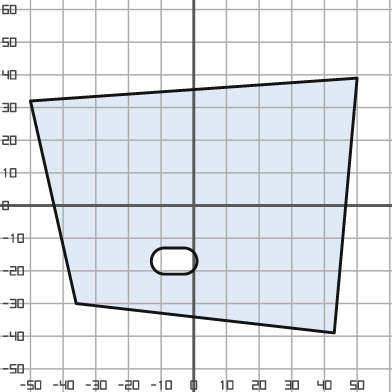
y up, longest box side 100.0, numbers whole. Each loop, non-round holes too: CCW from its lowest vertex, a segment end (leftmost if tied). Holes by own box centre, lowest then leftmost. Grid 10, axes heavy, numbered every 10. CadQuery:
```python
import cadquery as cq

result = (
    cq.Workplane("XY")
    .moveTo(43.0, -39.0)
    .lineTo(50.0, 39.0)
    .lineTo(-50.0, 32.0)
    .lineTo(-36.0, -30.0)
    .close()
    .moveTo(-9.0, -21.0)
    .lineTo(-3.0, -21.0)
    .threePointArc((1.0, -17.0), (-3.0, -13.0))
    .lineTo(-9.0, -13.0)
    .threePointArc((-13.0, -17.0), (-9.0, -21.0))
    .close()
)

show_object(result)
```